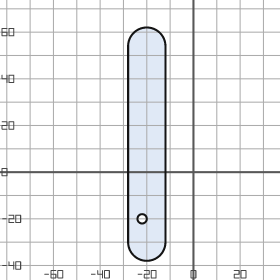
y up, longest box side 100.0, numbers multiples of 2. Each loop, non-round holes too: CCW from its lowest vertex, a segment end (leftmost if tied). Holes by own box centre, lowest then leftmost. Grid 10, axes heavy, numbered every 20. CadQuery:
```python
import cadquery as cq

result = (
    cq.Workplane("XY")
    .moveTo(-28.0, -30.0)
    .threePointArc((-20.0, -38.0), (-12.0, -30.0))
    .lineTo(-12.0, 54.0)
    .threePointArc((-20.0, 62.0), (-28.0, 54.0))
    .close()
    .moveTo(-22.0, -20.0)
    .circle(2.0)
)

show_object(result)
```